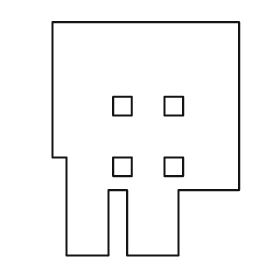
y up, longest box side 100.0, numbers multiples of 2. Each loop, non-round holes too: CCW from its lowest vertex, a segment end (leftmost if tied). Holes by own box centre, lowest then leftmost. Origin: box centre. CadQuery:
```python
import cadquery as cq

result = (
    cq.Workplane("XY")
    .moveTo(-34.0, -50.0)
    .lineTo(-16.0, -50.0)
    .lineTo(-16.0, -22.0)
    .lineTo(-8.0, -22.0)
    .lineTo(-8.0, -50.0)
    .lineTo(14.0, -50.0)
    .lineTo(14.0, -22.0)
    .lineTo(40.0, -22.0)
    .lineTo(40.0, 50.0)
    .lineTo(-40.0, 50.0)
    .lineTo(-40.0, -8.0)
    .lineTo(-34.0, -8.0)
    .close()
    .moveTo(-14.0, -16.0)
    .lineTo(-6.0, -16.0)
    .lineTo(-6.0, -8.0)
    .lineTo(-14.0, -8.0)
    .close()
    .moveTo(8.0, -16.0)
    .lineTo(16.0, -16.0)
    .lineTo(16.0, -8.0)
    .lineTo(8.0, -8.0)
    .close()
    .moveTo(-14.0, 10.0)
    .lineTo(-6.0, 10.0)
    .lineTo(-6.0, 18.0)
    .lineTo(-14.0, 18.0)
    .close()
    .moveTo(8.0, 10.0)
    .lineTo(16.0, 10.0)
    .lineTo(16.0, 18.0)
    .lineTo(8.0, 18.0)
    .close()
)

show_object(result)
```